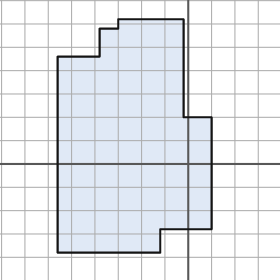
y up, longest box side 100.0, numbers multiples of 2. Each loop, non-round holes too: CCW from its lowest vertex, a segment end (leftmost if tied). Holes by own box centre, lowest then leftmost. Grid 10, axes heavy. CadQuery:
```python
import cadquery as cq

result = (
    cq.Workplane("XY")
    .moveTo(-56.0, -38.0)
    .lineTo(-12.0, -38.0)
    .lineTo(-12.0, -28.0)
    .lineTo(10.0, -28.0)
    .lineTo(10.0, 20.0)
    .lineTo(-2.0, 20.0)
    .lineTo(-2.0, 62.0)
    .lineTo(-30.0, 62.0)
    .lineTo(-30.0, 58.0)
    .lineTo(-38.0, 58.0)
    .lineTo(-38.0, 46.0)
    .lineTo(-56.0, 46.0)
    .close()
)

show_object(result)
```